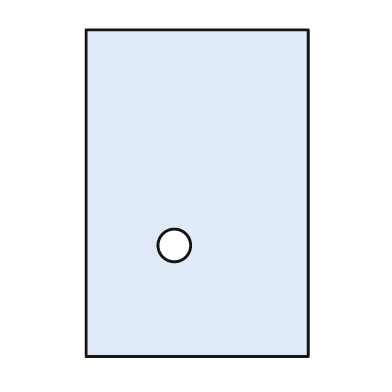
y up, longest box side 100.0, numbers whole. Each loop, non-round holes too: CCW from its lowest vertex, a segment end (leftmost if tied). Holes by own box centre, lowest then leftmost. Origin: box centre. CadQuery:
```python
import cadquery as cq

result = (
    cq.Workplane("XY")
    .moveTo(-34.0, -50.0)
    .lineTo(34.0, -50.0)
    .lineTo(34.0, 50.0)
    .lineTo(-34.0, 50.0)
    .close()
    .moveTo(-7.0, -16.0)
    .circle(5.0)
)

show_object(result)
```